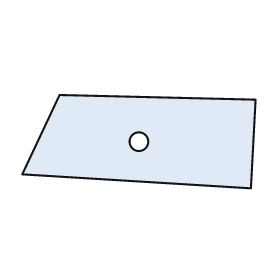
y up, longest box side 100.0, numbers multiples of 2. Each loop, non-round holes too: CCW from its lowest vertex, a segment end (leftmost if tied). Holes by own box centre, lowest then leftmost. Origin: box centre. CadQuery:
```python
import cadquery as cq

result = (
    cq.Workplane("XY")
    .moveTo(48.0, -20.0)
    .lineTo(50.0, 18.0)
    .lineTo(-34.0, 20.0)
    .lineTo(-50.0, -14.0)
    .close()
    .moveTo(0.0, 0.0)
    .circle(4.0)
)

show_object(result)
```